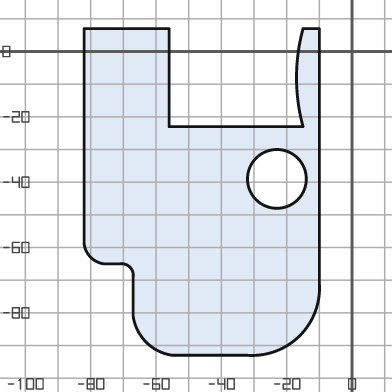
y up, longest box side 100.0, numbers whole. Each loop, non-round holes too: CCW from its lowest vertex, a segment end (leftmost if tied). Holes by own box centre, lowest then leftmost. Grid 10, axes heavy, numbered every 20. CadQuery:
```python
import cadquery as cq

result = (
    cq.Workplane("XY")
    .moveTo(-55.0, -93.0)
    .lineTo(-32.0, -93.0)
    .threePointArc((-16.0, -87.0), (-10.0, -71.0))
    .lineTo(-10.0, 7.0)
    .lineTo(-15.0, 7.0)
    .threePointArc((-17.0, -8.0), (-15.0, -23.0))
    .lineTo(-56.0, -23.0)
    .lineTo(-56.0, 7.0)
    .lineTo(-82.0, 7.0)
    .lineTo(-82.0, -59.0)
    .threePointArc((-80.0, -63.0), (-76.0, -65.0))
    .lineTo(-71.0, -65.0)
    .threePointArc((-68.0, -66.0), (-67.0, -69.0))
    .lineTo(-67.0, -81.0)
    .threePointArc((-63.0, -89.0), (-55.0, -93.0))
    .close()
    .moveTo(-23.0, -39.0)
    .circle(9.0)
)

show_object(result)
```